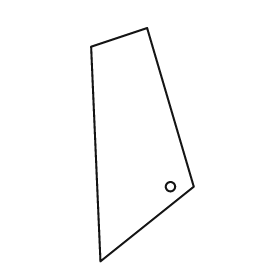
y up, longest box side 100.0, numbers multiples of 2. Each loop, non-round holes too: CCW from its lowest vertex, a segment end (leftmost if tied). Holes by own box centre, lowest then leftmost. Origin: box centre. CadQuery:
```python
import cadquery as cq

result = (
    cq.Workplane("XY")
    .moveTo(-18.0, -50.0)
    .lineTo(22.0, -18.0)
    .lineTo(2.0, 50.0)
    .lineTo(-22.0, 42.0)
    .close()
    .moveTo(12.0, -18.0)
    .circle(2.0)
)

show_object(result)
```